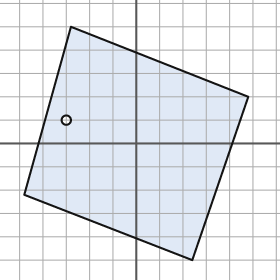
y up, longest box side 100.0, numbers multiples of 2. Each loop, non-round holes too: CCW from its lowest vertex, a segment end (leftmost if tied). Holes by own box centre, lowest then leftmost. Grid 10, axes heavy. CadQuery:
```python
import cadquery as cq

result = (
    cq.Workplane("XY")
    .moveTo(24.0, -50.0)
    .lineTo(48.0, 20.0)
    .lineTo(-28.0, 50.0)
    .lineTo(-48.0, -22.0)
    .close()
    .moveTo(-30.0, 10.0)
    .circle(2.0)
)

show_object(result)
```